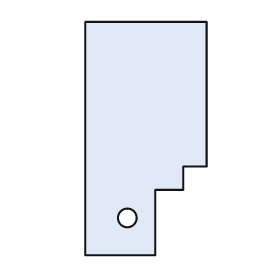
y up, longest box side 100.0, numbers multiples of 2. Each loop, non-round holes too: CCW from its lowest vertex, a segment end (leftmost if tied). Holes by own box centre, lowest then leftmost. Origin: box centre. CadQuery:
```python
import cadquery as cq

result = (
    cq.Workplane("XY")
    .moveTo(-26.0, -50.0)
    .lineTo(4.0, -50.0)
    .lineTo(4.0, -22.0)
    .lineTo(16.0, -22.0)
    .lineTo(16.0, -12.0)
    .lineTo(26.0, -12.0)
    .lineTo(26.0, 50.0)
    .lineTo(-26.0, 50.0)
    .close()
    .moveTo(-8.0, -34.0)
    .circle(4.0)
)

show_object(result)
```